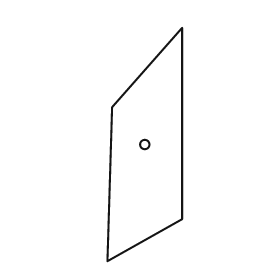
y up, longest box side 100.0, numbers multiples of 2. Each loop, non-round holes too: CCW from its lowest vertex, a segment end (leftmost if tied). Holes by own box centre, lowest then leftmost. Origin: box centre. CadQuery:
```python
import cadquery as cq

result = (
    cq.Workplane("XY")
    .moveTo(-16.0, -50.0)
    .lineTo(16.0, -32.0)
    .lineTo(16.0, 50.0)
    .lineTo(-14.0, 16.0)
    .close()
    .moveTo(0.0, 0.0)
    .circle(2.0)
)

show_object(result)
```